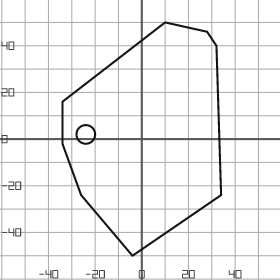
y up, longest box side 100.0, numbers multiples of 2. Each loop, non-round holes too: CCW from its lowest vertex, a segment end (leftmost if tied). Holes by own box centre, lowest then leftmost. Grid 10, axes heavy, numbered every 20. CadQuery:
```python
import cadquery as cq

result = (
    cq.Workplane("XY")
    .moveTo(-4.0, -50.0)
    .lineTo(34.0, -24.0)
    .lineTo(32.0, 40.0)
    .lineTo(28.0, 46.0)
    .lineTo(10.0, 50.0)
    .lineTo(-34.0, 16.0)
    .lineTo(-34.0, -2.0)
    .lineTo(-26.0, -24.0)
    .close()
    .moveTo(-24.0, 2.0)
    .circle(4.0)
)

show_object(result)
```